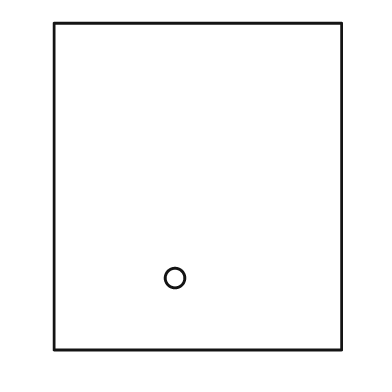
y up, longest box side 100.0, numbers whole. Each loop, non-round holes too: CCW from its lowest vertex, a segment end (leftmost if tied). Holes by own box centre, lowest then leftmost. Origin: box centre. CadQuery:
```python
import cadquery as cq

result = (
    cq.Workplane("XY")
    .moveTo(-44.0, -50.0)
    .lineTo(44.0, -50.0)
    .lineTo(44.0, 50.0)
    .lineTo(-44.0, 50.0)
    .close()
    .moveTo(-7.0, -28.0)
    .circle(3.0)
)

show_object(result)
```